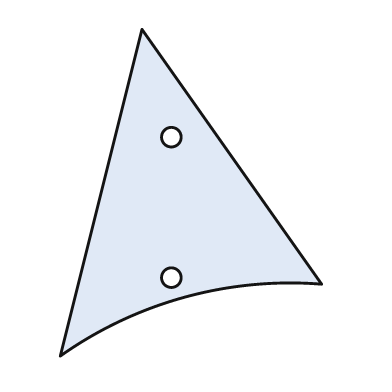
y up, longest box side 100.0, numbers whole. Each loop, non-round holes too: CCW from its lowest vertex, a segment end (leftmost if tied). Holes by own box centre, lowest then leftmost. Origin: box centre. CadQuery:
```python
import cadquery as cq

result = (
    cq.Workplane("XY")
    .moveTo(-40.0, -50.0)
    .threePointArc((-2.0, -32.0), (40.0, -28.0))
    .lineTo(-15.0, 50.0)
    .close()
    .moveTo(-6.0, -26.0)
    .circle(3.0)
    .moveTo(-6.0, 17.0)
    .circle(3.0)
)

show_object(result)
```